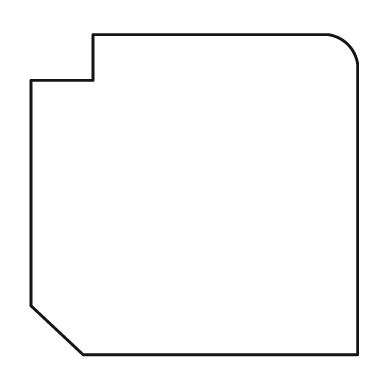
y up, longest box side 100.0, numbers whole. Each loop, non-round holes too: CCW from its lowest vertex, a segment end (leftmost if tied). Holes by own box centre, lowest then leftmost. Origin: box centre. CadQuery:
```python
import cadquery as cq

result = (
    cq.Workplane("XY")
    .moveTo(-34.0, -49.0)
    .lineTo(50.0, -49.0)
    .lineTo(50.0, 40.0)
    .threePointArc((47.0, 46.0), (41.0, 49.0))
    .lineTo(-31.0, 49.0)
    .lineTo(-31.0, 35.0)
    .lineTo(-50.0, 35.0)
    .lineTo(-50.0, -34.0)
    .close()
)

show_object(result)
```